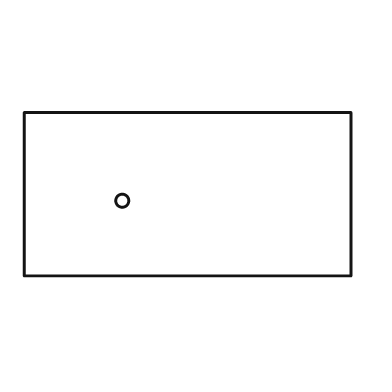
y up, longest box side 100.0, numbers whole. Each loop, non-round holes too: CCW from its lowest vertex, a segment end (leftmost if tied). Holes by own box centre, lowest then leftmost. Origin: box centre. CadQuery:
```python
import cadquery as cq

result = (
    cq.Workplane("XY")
    .moveTo(-50.0, -25.0)
    .lineTo(50.0, -25.0)
    .lineTo(50.0, 25.0)
    .lineTo(-50.0, 25.0)
    .close()
    .moveTo(-20.0, -2.0)
    .circle(2.0)
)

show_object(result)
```